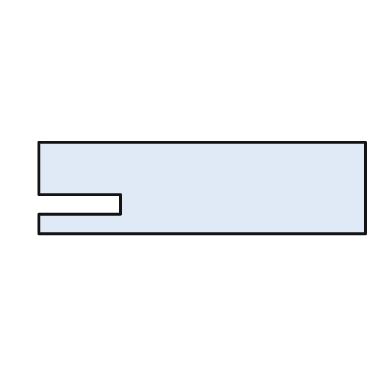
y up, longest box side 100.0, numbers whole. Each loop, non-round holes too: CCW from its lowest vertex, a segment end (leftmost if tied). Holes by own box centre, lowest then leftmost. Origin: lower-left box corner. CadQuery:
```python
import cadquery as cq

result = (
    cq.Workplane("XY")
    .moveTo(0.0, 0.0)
    .lineTo(100.0, 0.0)
    .lineTo(100.0, 28.0)
    .lineTo(0.0, 28.0)
    .lineTo(0.0, 12.0)
    .lineTo(25.0, 12.0)
    .lineTo(25.0, 6.0)
    .lineTo(0.0, 6.0)
    .close()
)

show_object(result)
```